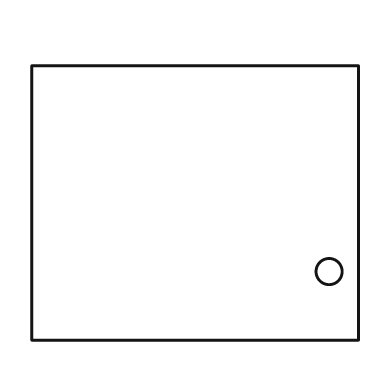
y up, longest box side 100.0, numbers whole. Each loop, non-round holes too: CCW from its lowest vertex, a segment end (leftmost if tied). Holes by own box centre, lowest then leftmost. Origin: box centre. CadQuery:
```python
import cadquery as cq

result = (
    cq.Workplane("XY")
    .moveTo(-50.0, -42.0)
    .lineTo(50.0, -42.0)
    .lineTo(50.0, 42.0)
    .lineTo(-50.0, 42.0)
    .close()
    .moveTo(41.0, -21.0)
    .circle(4.0)
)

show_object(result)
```